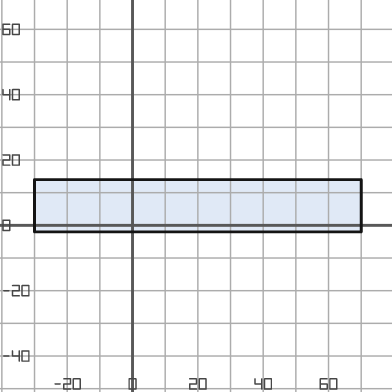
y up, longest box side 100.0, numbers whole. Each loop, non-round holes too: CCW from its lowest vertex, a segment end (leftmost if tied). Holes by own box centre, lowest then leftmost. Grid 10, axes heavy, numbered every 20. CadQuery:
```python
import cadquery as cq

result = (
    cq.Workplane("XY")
    .moveTo(-30.0, -2.0)
    .lineTo(70.0, -2.0)
    .lineTo(70.0, 14.0)
    .lineTo(-30.0, 14.0)
    .close()
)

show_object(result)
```